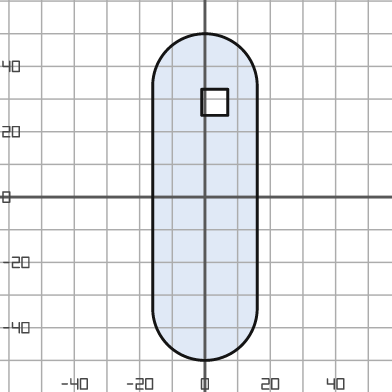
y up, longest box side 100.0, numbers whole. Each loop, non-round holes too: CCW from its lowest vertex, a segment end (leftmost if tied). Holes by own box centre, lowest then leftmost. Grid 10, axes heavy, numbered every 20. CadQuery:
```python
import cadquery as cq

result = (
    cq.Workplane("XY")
    .moveTo(-16.0, -34.0)
    .threePointArc((0.0, -50.0), (16.0, -34.0))
    .lineTo(16.0, 34.0)
    .threePointArc((0.0, 50.0), (-16.0, 34.0))
    .close()
    .moveTo(-1.0, 25.0)
    .lineTo(7.0, 25.0)
    .lineTo(7.0, 33.0)
    .lineTo(-1.0, 33.0)
    .close()
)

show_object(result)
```